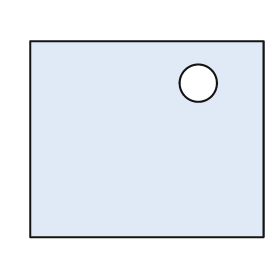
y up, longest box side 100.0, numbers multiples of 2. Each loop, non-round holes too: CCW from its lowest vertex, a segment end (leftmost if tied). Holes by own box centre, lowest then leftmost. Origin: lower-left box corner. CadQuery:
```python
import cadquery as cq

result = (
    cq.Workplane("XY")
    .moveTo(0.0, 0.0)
    .lineTo(100.0, 0.0)
    .lineTo(100.0, 84.0)
    .lineTo(0.0, 84.0)
    .close()
    .moveTo(72.0, 66.0)
    .circle(8.0)
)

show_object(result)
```